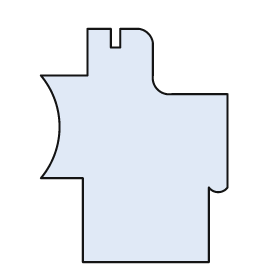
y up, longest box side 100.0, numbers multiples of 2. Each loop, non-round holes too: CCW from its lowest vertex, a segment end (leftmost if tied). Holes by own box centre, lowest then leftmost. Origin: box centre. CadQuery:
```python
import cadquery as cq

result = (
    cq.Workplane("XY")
    .moveTo(-22.0, -50.0)
    .lineTo(32.0, -50.0)
    .lineTo(32.0, -18.0)
    .threePointArc((36.0, -20.0), (40.0, -18.0))
    .lineTo(40.0, 22.0)
    .lineTo(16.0, 22.0)
    .threePointArc((10.0, 24.0), (8.0, 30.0))
    .lineTo(8.0, 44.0)
    .threePointArc((6.0, 48.0), (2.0, 50.0))
    .lineTo(-6.0, 50.0)
    .lineTo(-6.0, 42.0)
    .lineTo(-10.0, 42.0)
    .lineTo(-10.0, 50.0)
    .lineTo(-20.0, 50.0)
    .lineTo(-20.0, 30.0)
    .lineTo(-40.0, 30.0)
    .threePointArc((-32.0, 8.0), (-40.0, -14.0))
    .lineTo(-22.0, -14.0)
    .close()
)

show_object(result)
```